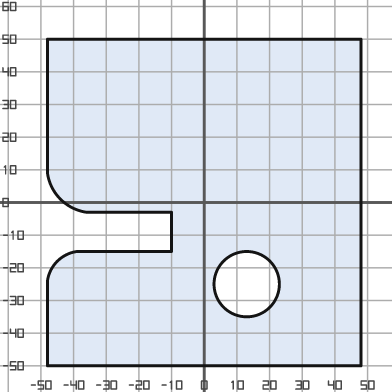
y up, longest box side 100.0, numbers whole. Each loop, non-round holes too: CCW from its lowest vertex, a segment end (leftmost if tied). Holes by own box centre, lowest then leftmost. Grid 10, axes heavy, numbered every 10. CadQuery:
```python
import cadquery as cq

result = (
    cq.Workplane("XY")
    .moveTo(-48.0, -50.0)
    .lineTo(48.0, -50.0)
    .lineTo(48.0, 50.0)
    .lineTo(-48.0, 50.0)
    .lineTo(-48.0, 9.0)
    .threePointArc((-44.0, 1.0), (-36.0, -3.0))
    .lineTo(-10.0, -3.0)
    .lineTo(-10.0, -15.0)
    .lineTo(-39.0, -15.0)
    .threePointArc((-45.0, -18.0), (-48.0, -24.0))
    .close()
    .moveTo(13.0, -25.0)
    .circle(10.0)
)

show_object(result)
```